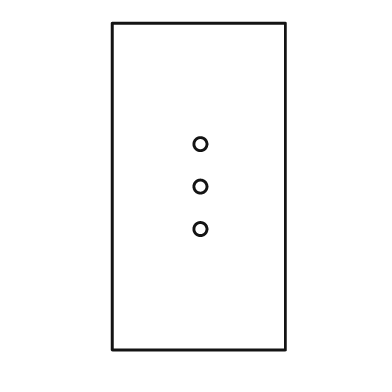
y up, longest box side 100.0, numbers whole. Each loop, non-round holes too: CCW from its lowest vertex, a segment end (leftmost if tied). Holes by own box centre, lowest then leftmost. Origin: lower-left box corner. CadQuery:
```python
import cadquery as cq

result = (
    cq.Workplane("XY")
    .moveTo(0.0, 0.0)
    .lineTo(53.0, 0.0)
    .lineTo(53.0, 100.0)
    .lineTo(0.0, 100.0)
    .close()
    .moveTo(27.0, 37.0)
    .circle(2.0)
    .moveTo(27.0, 50.0)
    .circle(2.0)
    .moveTo(27.0, 63.0)
    .circle(2.0)
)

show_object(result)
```